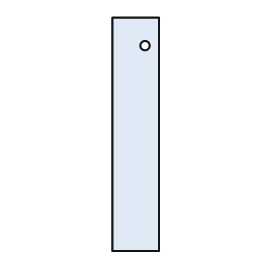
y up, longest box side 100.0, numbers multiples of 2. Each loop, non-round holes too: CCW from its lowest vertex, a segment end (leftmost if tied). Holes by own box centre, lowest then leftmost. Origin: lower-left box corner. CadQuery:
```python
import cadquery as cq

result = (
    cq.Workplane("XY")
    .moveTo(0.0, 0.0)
    .lineTo(20.0, 0.0)
    .lineTo(20.0, 100.0)
    .lineTo(0.0, 100.0)
    .close()
    .moveTo(14.0, 88.0)
    .circle(2.0)
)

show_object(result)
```